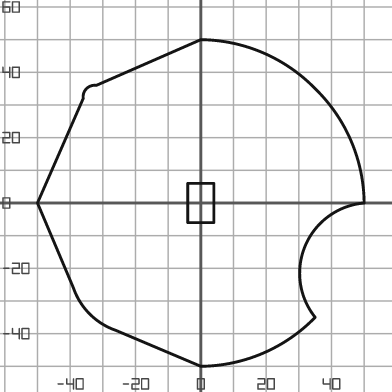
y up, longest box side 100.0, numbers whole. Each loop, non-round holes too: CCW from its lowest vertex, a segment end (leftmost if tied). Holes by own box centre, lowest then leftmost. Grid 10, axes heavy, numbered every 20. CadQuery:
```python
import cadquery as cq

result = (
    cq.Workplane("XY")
    .moveTo(0.0, -50.0)
    .threePointArc((19.0, -46.0), (35.0, -35.0))
    .threePointArc((32.0, -13.0), (50.0, 0.0))
    .threePointArc((46.0, 19.0), (35.0, 35.0))
    .threePointArc((19.0, 46.0), (0.0, 50.0))
    .lineTo(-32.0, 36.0)
    .threePointArc((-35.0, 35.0), (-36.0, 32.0))
    .lineTo(-50.0, 0.0)
    .lineTo(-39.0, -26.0)
    .threePointArc((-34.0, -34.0), (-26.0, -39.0))
    .close()
    .moveTo(-4.0, -6.0)
    .lineTo(4.0, -6.0)
    .lineTo(4.0, 6.0)
    .lineTo(-4.0, 6.0)
    .close()
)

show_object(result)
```